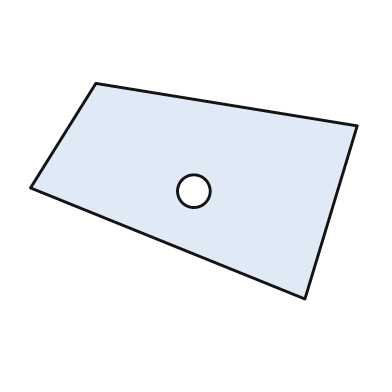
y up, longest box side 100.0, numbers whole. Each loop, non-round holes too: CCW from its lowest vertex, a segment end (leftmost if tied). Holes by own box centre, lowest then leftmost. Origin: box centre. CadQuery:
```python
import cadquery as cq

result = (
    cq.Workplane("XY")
    .moveTo(34.0, -33.0)
    .lineTo(50.0, 20.0)
    .lineTo(-30.0, 33.0)
    .lineTo(-50.0, 1.0)
    .close()
    .moveTo(0.0, 0.0)
    .circle(5.0)
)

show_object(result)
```